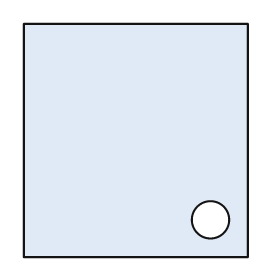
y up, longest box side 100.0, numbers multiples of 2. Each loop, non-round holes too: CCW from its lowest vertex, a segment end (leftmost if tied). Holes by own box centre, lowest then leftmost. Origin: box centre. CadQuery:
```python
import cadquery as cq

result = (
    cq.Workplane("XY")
    .moveTo(-48.0, -50.0)
    .lineTo(48.0, -50.0)
    .lineTo(48.0, 50.0)
    .lineTo(-48.0, 50.0)
    .close()
    .moveTo(32.0, -34.0)
    .circle(8.0)
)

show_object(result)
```